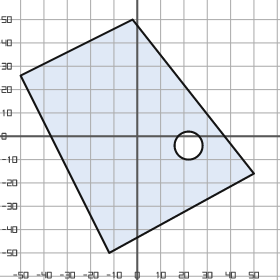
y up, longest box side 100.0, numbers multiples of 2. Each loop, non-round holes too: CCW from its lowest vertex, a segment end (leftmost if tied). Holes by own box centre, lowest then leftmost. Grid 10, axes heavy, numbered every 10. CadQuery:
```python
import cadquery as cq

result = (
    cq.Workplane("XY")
    .moveTo(-12.0, -50.0)
    .lineTo(50.0, -16.0)
    .lineTo(-2.0, 50.0)
    .lineTo(-50.0, 26.0)
    .close()
    .moveTo(22.0, -4.0)
    .circle(6.0)
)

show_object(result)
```